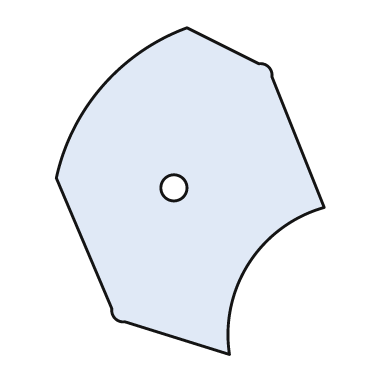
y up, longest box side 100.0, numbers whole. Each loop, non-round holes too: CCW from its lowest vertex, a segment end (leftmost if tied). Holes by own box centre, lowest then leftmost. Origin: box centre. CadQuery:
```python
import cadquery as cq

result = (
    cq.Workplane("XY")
    .moveTo(12.0, -50.0)
    .threePointArc((18.0, -22.0), (41.0, -5.0))
    .lineTo(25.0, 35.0)
    .threePointArc((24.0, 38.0), (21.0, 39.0))
    .lineTo(-1.0, 50.0)
    .threePointArc((-27.0, 32.0), (-41.0, 4.0))
    .lineTo(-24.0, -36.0)
    .threePointArc((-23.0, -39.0), (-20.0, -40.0))
    .close()
    .moveTo(-5.0, 1.0)
    .circle(4.0)
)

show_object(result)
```